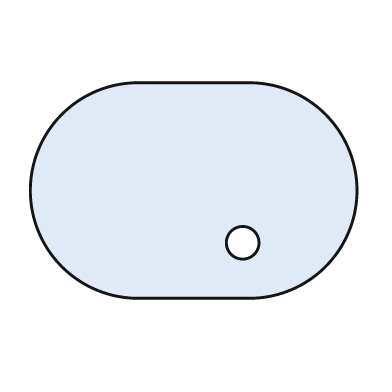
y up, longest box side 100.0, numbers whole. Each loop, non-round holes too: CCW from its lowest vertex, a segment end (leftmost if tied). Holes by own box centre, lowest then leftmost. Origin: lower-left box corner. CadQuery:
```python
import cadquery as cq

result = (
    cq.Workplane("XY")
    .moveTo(33.0, 0.0)
    .lineTo(67.0, 0.0)
    .threePointArc((100.0, 33.0), (67.0, 66.0))
    .lineTo(33.0, 66.0)
    .threePointArc((0.0, 33.0), (33.0, 0.0))
    .close()
    .moveTo(65.0, 17.0)
    .circle(5.0)
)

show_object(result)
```